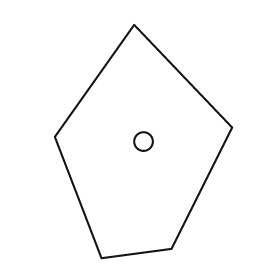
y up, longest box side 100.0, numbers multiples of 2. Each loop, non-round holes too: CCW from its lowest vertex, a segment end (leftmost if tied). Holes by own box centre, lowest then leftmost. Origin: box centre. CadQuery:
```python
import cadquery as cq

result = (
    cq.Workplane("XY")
    .moveTo(-18.0, -50.0)
    .lineTo(12.0, -46.0)
    .lineTo(38.0, 6.0)
    .lineTo(-4.0, 50.0)
    .lineTo(-38.0, 2.0)
    .close()
    .moveTo(0.0, 0.0)
    .circle(4.0)
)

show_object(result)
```